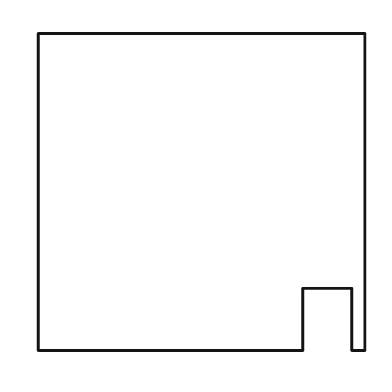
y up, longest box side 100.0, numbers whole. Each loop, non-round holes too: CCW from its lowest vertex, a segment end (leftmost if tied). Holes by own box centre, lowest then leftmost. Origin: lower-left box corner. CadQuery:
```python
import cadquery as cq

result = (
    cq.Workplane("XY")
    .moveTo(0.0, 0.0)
    .lineTo(81.0, 0.0)
    .lineTo(81.0, 19.0)
    .lineTo(96.0, 19.0)
    .lineTo(96.0, 0.0)
    .lineTo(100.0, 0.0)
    .lineTo(100.0, 97.0)
    .lineTo(0.0, 97.0)
    .close()
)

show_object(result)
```